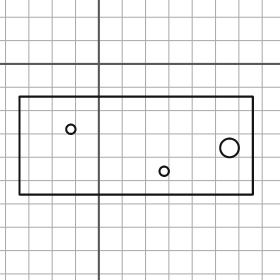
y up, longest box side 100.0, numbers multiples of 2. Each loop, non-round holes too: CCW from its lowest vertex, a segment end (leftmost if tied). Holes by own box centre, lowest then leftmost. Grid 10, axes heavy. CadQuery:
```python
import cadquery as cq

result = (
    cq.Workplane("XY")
    .moveTo(-34.0, -56.0)
    .lineTo(66.0, -56.0)
    .lineTo(66.0, -14.0)
    .lineTo(-34.0, -14.0)
    .close()
    .moveTo(28.0, -46.0)
    .circle(2.0)
    .moveTo(56.0, -36.0)
    .circle(4.0)
    .moveTo(-12.0, -28.0)
    .circle(2.0)
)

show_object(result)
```